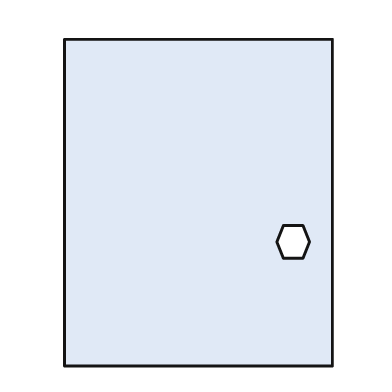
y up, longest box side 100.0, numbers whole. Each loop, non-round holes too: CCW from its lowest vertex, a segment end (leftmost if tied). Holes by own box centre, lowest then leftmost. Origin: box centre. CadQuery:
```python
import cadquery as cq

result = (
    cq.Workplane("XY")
    .moveTo(-41.0, -50.0)
    .lineTo(41.0, -50.0)
    .lineTo(41.0, 50.0)
    .lineTo(-41.0, 50.0)
    .close()
    .moveTo(26.0, -17.0)
    .lineTo(32.0, -17.0)
    .lineTo(34.0, -12.0)
    .lineTo(32.0, -7.0)
    .lineTo(26.0, -7.0)
    .lineTo(24.0, -12.0)
    .close()
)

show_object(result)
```